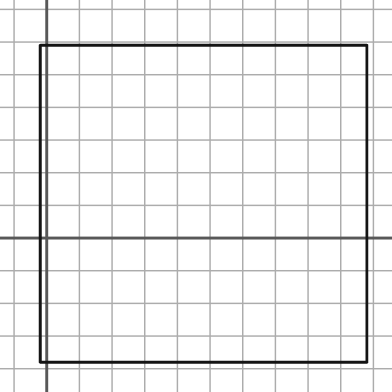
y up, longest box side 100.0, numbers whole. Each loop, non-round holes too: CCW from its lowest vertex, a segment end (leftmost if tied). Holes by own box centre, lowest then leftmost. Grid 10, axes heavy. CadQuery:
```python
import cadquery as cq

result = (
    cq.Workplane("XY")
    .moveTo(-2.0, -38.0)
    .lineTo(98.0, -38.0)
    .lineTo(98.0, 59.0)
    .lineTo(-2.0, 59.0)
    .close()
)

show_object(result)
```